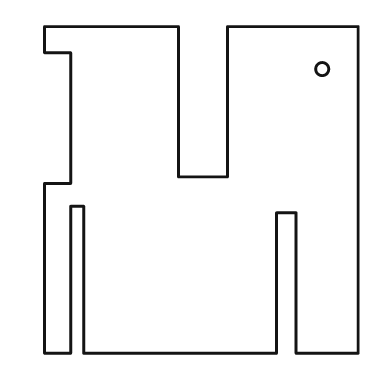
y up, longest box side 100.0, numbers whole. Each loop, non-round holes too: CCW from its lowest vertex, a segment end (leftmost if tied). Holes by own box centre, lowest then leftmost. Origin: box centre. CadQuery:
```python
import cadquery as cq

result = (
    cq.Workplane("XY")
    .moveTo(-48.0, -50.0)
    .lineTo(-40.0, -50.0)
    .lineTo(-40.0, -5.0)
    .lineTo(-36.0, -5.0)
    .lineTo(-36.0, -50.0)
    .lineTo(23.0, -50.0)
    .lineTo(23.0, -7.0)
    .lineTo(29.0, -7.0)
    .lineTo(29.0, -50.0)
    .lineTo(48.0, -50.0)
    .lineTo(48.0, 50.0)
    .lineTo(8.0, 50.0)
    .lineTo(8.0, 4.0)
    .lineTo(-7.0, 4.0)
    .lineTo(-7.0, 50.0)
    .lineTo(-48.0, 50.0)
    .lineTo(-48.0, 42.0)
    .lineTo(-40.0, 42.0)
    .lineTo(-40.0, 2.0)
    .lineTo(-48.0, 2.0)
    .close()
    .moveTo(37.0, 37.0)
    .circle(2.0)
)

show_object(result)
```